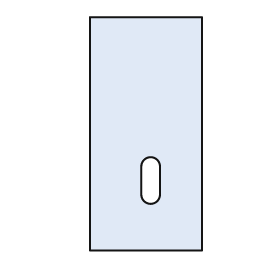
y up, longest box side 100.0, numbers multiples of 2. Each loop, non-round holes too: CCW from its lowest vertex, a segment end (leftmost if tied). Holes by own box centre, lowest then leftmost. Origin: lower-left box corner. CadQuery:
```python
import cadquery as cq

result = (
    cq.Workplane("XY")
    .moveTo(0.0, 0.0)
    .lineTo(48.0, 0.0)
    .lineTo(48.0, 100.0)
    .lineTo(0.0, 100.0)
    .close()
    .moveTo(22.0, 24.0)
    .threePointArc((26.0, 20.0), (30.0, 24.0))
    .lineTo(30.0, 36.0)
    .threePointArc((26.0, 40.0), (22.0, 36.0))
    .close()
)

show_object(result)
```